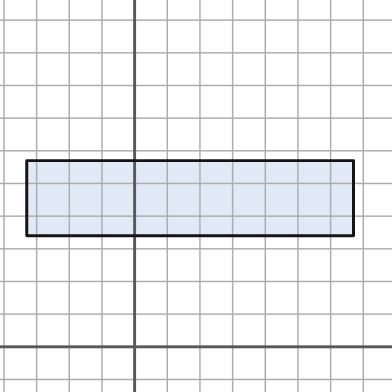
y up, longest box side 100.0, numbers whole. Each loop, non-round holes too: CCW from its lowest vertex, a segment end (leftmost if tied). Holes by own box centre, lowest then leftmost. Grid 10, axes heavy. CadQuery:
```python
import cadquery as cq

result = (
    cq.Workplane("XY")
    .moveTo(-33.0, 34.0)
    .lineTo(67.0, 34.0)
    .lineTo(67.0, 57.0)
    .lineTo(-33.0, 57.0)
    .close()
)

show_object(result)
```